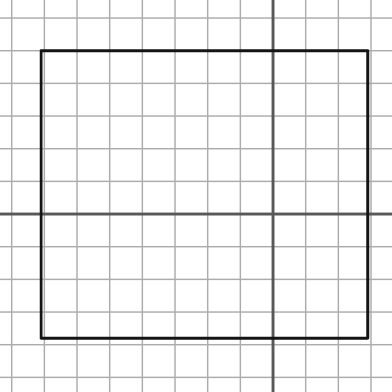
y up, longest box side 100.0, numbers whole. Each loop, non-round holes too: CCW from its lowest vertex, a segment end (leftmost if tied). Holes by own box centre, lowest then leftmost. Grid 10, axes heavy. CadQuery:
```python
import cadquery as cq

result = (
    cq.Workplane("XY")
    .moveTo(-71.0, -38.0)
    .lineTo(29.0, -38.0)
    .lineTo(29.0, 50.0)
    .lineTo(-71.0, 50.0)
    .close()
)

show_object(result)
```